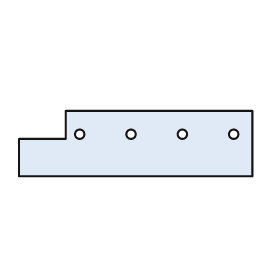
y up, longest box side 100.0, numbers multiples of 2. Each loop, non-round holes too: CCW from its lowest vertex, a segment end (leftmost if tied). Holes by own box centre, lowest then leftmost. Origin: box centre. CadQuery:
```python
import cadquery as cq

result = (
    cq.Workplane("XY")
    .moveTo(-50.0, -14.0)
    .lineTo(50.0, -14.0)
    .lineTo(50.0, 14.0)
    .lineTo(-30.0, 14.0)
    .lineTo(-30.0, 2.0)
    .lineTo(-50.0, 2.0)
    .close()
    .moveTo(-24.0, 4.0)
    .circle(2.0)
    .moveTo(-2.0, 4.0)
    .circle(2.0)
    .moveTo(20.0, 4.0)
    .circle(2.0)
    .moveTo(42.0, 4.0)
    .circle(2.0)
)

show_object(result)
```